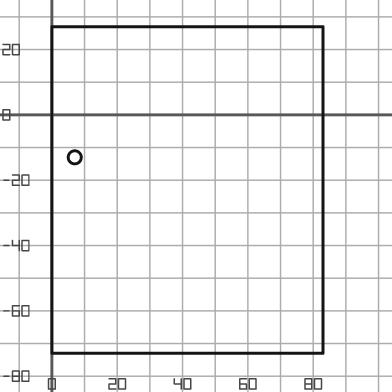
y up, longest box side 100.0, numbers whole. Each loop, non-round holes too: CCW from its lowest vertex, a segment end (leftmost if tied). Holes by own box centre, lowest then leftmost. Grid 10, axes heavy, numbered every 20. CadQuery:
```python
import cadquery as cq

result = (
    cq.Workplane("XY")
    .moveTo(0.0, -73.0)
    .lineTo(83.0, -73.0)
    .lineTo(83.0, 27.0)
    .lineTo(0.0, 27.0)
    .close()
    .moveTo(7.0, -13.0)
    .circle(2.0)
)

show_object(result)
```